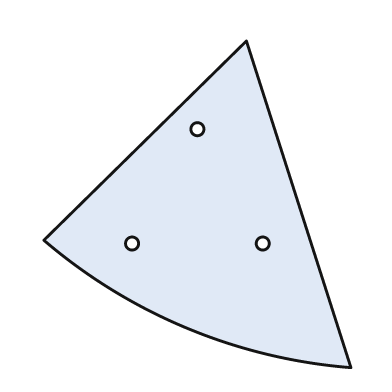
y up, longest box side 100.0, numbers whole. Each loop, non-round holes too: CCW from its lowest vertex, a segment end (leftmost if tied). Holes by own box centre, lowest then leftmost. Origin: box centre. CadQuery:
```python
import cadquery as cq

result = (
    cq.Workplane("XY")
    .moveTo(47.0, -50.0)
    .lineTo(15.0, 50.0)
    .lineTo(-47.0, -11.0)
    .threePointArc((-3.0, -38.0), (47.0, -50.0))
    .close()
    .moveTo(-20.0, -12.0)
    .circle(2.0)
    .moveTo(20.0, -12.0)
    .circle(2.0)
    .moveTo(0.0, 23.0)
    .circle(2.0)
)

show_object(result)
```